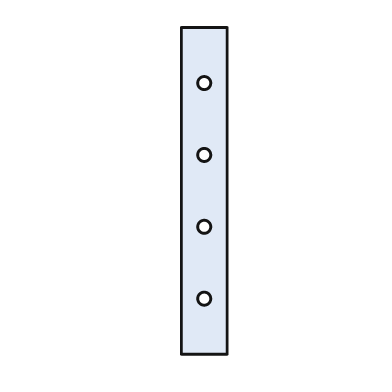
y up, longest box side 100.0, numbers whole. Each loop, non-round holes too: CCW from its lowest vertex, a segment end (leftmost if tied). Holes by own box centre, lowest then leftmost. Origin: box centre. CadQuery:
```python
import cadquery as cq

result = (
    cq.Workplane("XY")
    .moveTo(-7.0, -50.0)
    .lineTo(7.0, -50.0)
    .lineTo(7.0, 50.0)
    .lineTo(-7.0, 50.0)
    .close()
    .moveTo(0.0, -33.0)
    .circle(2.0)
    .moveTo(0.0, -11.0)
    .circle(2.0)
    .moveTo(0.0, 11.0)
    .circle(2.0)
    .moveTo(0.0, 33.0)
    .circle(2.0)
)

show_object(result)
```